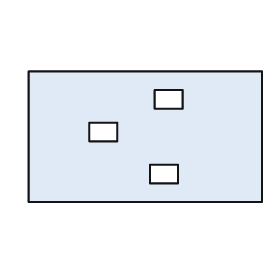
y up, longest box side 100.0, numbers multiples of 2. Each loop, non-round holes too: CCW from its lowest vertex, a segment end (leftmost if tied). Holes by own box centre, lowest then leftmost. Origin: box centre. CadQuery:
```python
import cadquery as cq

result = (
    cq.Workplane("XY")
    .moveTo(-50.0, -28.0)
    .lineTo(50.0, -28.0)
    .lineTo(50.0, 28.0)
    .lineTo(-50.0, 28.0)
    .close()
    .moveTo(2.0, -20.0)
    .lineTo(14.0, -20.0)
    .lineTo(14.0, -12.0)
    .lineTo(2.0, -12.0)
    .close()
    .moveTo(-24.0, -2.0)
    .lineTo(-12.0, -2.0)
    .lineTo(-12.0, 6.0)
    .lineTo(-24.0, 6.0)
    .close()
    .moveTo(4.0, 12.0)
    .lineTo(16.0, 12.0)
    .lineTo(16.0, 20.0)
    .lineTo(4.0, 20.0)
    .close()
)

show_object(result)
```